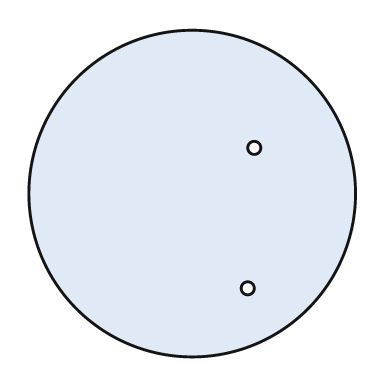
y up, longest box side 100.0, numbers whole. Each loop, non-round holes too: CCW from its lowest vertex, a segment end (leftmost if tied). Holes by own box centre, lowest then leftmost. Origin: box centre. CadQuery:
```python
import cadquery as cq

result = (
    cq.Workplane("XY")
    .moveTo(0.0, 0.0)
    .circle(50.0)
    .moveTo(17.0, -29.0)
    .circle(2.0)
    .moveTo(19.0, 14.0)
    .circle(2.0)
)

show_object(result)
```